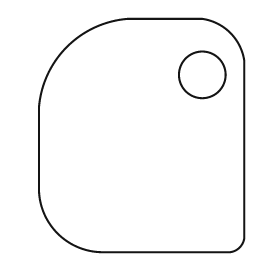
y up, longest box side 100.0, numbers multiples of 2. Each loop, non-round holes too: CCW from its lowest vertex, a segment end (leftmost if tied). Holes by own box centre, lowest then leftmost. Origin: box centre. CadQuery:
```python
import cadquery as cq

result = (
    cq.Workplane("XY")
    .moveTo(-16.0, -50.0)
    .lineTo(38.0, -50.0)
    .threePointArc((42.0, -48.0), (44.0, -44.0))
    .lineTo(44.0, 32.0)
    .threePointArc((38.0, 44.0), (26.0, 50.0))
    .lineTo(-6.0, 50.0)
    .threePointArc((-32.0, 38.0), (-44.0, 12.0))
    .lineTo(-44.0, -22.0)
    .threePointArc((-36.0, -42.0), (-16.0, -50.0))
    .close()
    .moveTo(26.0, 26.0)
    .circle(10.0)
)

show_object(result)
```